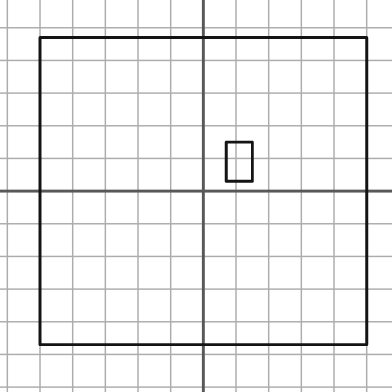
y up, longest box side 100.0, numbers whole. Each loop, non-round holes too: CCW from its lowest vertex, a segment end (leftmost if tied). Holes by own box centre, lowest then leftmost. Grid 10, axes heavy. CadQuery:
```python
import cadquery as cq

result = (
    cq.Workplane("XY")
    .moveTo(-50.0, -47.0)
    .lineTo(50.0, -47.0)
    .lineTo(50.0, 47.0)
    .lineTo(-50.0, 47.0)
    .close()
    .moveTo(7.0, 3.0)
    .lineTo(15.0, 3.0)
    .lineTo(15.0, 15.0)
    .lineTo(7.0, 15.0)
    .close()
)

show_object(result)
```